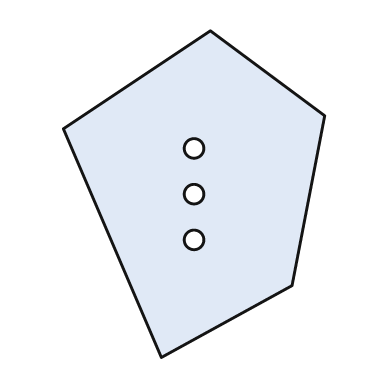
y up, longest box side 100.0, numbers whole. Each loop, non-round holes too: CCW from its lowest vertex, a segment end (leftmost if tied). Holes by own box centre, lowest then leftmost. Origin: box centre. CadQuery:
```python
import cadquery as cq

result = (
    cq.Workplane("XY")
    .moveTo(-10.0, -50.0)
    .lineTo(30.0, -28.0)
    .lineTo(40.0, 24.0)
    .lineTo(5.0, 50.0)
    .lineTo(-40.0, 20.0)
    .close()
    .moveTo(0.0, -14.0)
    .circle(3.0)
    .moveTo(0.0, 0.0)
    .circle(3.0)
    .moveTo(0.0, 14.0)
    .circle(3.0)
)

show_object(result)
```